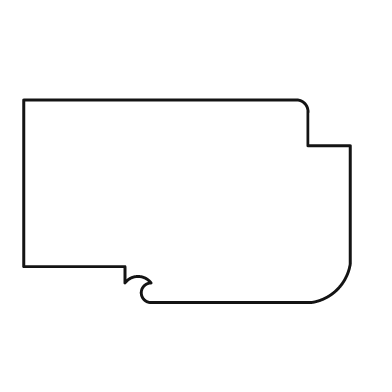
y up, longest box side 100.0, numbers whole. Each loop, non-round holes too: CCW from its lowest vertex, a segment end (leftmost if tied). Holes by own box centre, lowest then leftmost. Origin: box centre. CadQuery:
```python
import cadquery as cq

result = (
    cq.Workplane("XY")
    .moveTo(-11.0, -31.0)
    .lineTo(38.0, -31.0)
    .threePointArc((46.0, -27.0), (50.0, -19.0))
    .lineTo(50.0, 17.0)
    .lineTo(37.0, 17.0)
    .lineTo(37.0, 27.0)
    .threePointArc((36.0, 30.0), (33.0, 31.0))
    .lineTo(-50.0, 31.0)
    .lineTo(-50.0, -20.0)
    .lineTo(-19.0, -20.0)
    .lineTo(-19.0, -25.0)
    .threePointArc((-15.0, -23.0), (-11.0, -25.0))
    .threePointArc((-14.0, -28.0), (-11.0, -31.0))
    .close()
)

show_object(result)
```